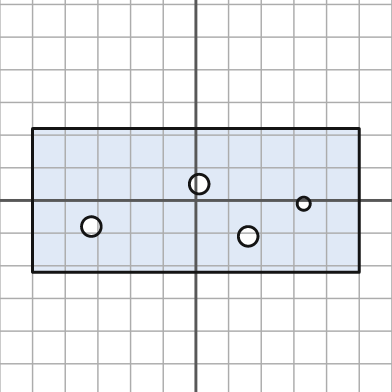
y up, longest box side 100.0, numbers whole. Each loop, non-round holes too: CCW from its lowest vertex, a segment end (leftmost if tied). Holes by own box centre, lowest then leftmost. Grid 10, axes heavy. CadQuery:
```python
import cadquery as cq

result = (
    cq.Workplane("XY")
    .moveTo(-50.0, -22.0)
    .lineTo(50.0, -22.0)
    .lineTo(50.0, 22.0)
    .lineTo(-50.0, 22.0)
    .close()
    .moveTo(16.0, -11.0)
    .circle(3.0)
    .moveTo(-32.0, -8.0)
    .circle(3.0)
    .moveTo(33.0, -1.0)
    .circle(2.0)
    .moveTo(1.0, 5.0)
    .circle(3.0)
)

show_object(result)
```